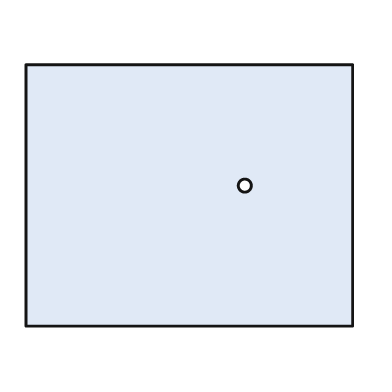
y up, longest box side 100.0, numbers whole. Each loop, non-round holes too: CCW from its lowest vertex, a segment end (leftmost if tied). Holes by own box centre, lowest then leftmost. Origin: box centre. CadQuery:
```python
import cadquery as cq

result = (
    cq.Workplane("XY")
    .moveTo(-50.0, -40.0)
    .lineTo(50.0, -40.0)
    .lineTo(50.0, 40.0)
    .lineTo(-50.0, 40.0)
    .close()
    .moveTo(17.0, 3.0)
    .circle(2.0)
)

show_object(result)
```